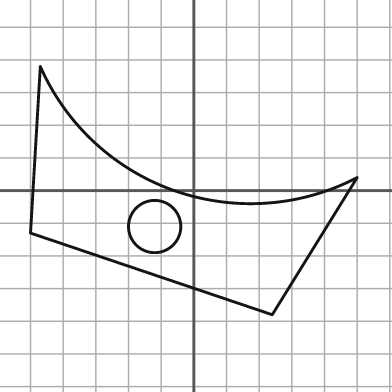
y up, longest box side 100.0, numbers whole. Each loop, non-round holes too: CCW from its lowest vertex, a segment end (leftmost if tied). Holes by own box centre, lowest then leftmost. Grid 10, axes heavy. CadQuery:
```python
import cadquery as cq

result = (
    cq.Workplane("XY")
    .moveTo(24.0, -38.0)
    .lineTo(50.0, 4.0)
    .threePointArc((-6.0, 0.0), (-47.0, 38.0))
    .lineTo(-50.0, -13.0)
    .close()
    .moveTo(-12.0, -11.0)
    .circle(8.0)
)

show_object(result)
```